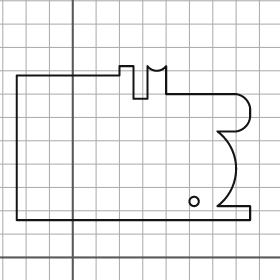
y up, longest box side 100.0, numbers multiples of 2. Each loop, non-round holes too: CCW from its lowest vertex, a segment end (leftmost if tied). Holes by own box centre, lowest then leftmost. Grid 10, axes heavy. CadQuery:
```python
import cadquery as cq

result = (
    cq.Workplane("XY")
    .moveTo(-24.0, 16.0)
    .lineTo(76.0, 16.0)
    .lineTo(76.0, 22.0)
    .lineTo(62.0, 22.0)
    .threePointArc((70.0, 38.0), (62.0, 54.0))
    .lineTo(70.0, 54.0)
    .threePointArc((74.0, 56.0), (76.0, 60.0))
    .lineTo(76.0, 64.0)
    .threePointArc((74.0, 68.0), (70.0, 70.0))
    .lineTo(40.0, 70.0)
    .lineTo(40.0, 82.0)
    .threePointArc((36.0, 80.0), (32.0, 82.0))
    .lineTo(32.0, 68.0)
    .lineTo(26.0, 68.0)
    .lineTo(26.0, 82.0)
    .lineTo(20.0, 82.0)
    .lineTo(20.0, 78.0)
    .lineTo(-24.0, 78.0)
    .close()
    .moveTo(52.0, 24.0)
    .circle(2.0)
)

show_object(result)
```